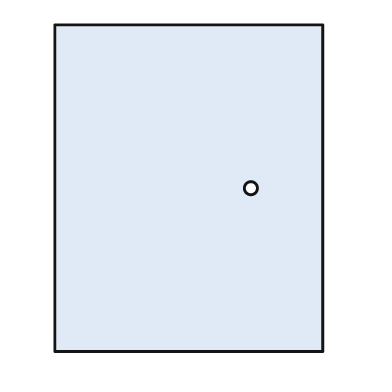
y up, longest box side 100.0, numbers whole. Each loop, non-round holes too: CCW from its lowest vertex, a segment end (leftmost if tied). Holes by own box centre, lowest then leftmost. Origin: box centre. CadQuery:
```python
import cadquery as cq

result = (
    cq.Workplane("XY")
    .moveTo(-41.0, -50.0)
    .lineTo(41.0, -50.0)
    .lineTo(41.0, 50.0)
    .lineTo(-41.0, 50.0)
    .close()
    .moveTo(19.0, 0.0)
    .circle(2.0)
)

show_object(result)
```